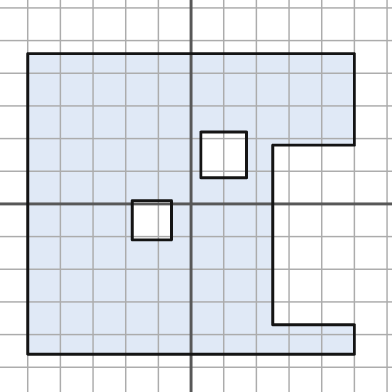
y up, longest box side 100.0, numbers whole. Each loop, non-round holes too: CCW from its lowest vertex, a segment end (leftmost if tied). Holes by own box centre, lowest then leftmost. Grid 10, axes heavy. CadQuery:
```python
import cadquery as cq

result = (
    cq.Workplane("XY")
    .moveTo(-50.0, -46.0)
    .lineTo(50.0, -46.0)
    .lineTo(50.0, -37.0)
    .lineTo(25.0, -37.0)
    .lineTo(25.0, 18.0)
    .lineTo(50.0, 18.0)
    .lineTo(50.0, 46.0)
    .lineTo(-50.0, 46.0)
    .close()
    .moveTo(-18.0, -11.0)
    .lineTo(-6.0, -11.0)
    .lineTo(-6.0, 1.0)
    .lineTo(-18.0, 1.0)
    .close()
    .moveTo(3.0, 8.0)
    .lineTo(17.0, 8.0)
    .lineTo(17.0, 22.0)
    .lineTo(3.0, 22.0)
    .close()
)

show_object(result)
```